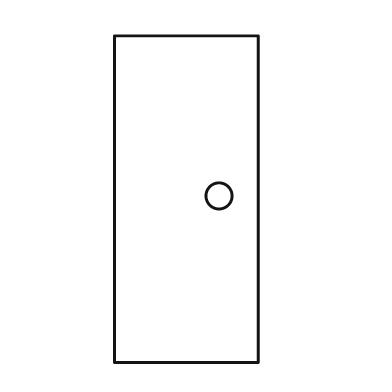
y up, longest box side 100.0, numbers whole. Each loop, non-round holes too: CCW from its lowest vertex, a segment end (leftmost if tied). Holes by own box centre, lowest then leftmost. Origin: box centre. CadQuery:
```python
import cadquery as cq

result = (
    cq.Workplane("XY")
    .moveTo(-22.0, -50.0)
    .lineTo(22.0, -50.0)
    .lineTo(22.0, 50.0)
    .lineTo(-22.0, 50.0)
    .close()
    .moveTo(10.0, 1.0)
    .circle(4.0)
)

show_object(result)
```